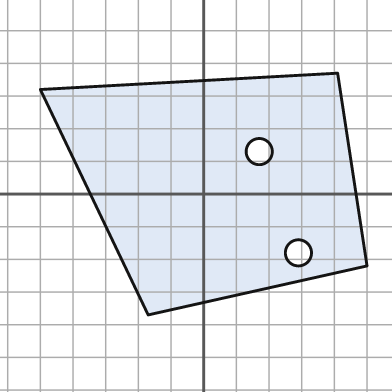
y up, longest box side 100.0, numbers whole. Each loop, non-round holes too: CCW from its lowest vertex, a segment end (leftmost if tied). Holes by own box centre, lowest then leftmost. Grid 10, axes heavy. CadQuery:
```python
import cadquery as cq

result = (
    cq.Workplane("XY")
    .moveTo(-17.0, -37.0)
    .lineTo(50.0, -22.0)
    .lineTo(41.0, 37.0)
    .lineTo(-50.0, 32.0)
    .close()
    .moveTo(29.0, -18.0)
    .circle(4.0)
    .moveTo(17.0, 13.0)
    .circle(4.0)
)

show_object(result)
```